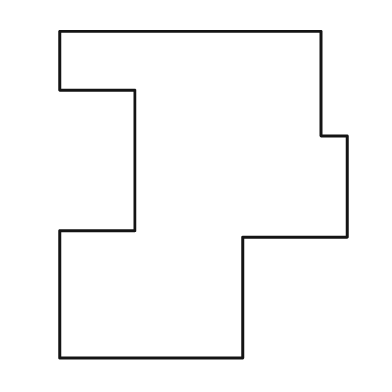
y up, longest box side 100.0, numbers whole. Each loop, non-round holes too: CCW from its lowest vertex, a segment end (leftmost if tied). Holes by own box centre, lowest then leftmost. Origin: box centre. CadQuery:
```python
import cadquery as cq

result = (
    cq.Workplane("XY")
    .moveTo(-44.0, -50.0)
    .lineTo(12.0, -50.0)
    .lineTo(12.0, -13.0)
    .lineTo(44.0, -13.0)
    .lineTo(44.0, 18.0)
    .lineTo(36.0, 18.0)
    .lineTo(36.0, 50.0)
    .lineTo(-44.0, 50.0)
    .lineTo(-44.0, 32.0)
    .lineTo(-21.0, 32.0)
    .lineTo(-21.0, -11.0)
    .lineTo(-44.0, -11.0)
    .close()
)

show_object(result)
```